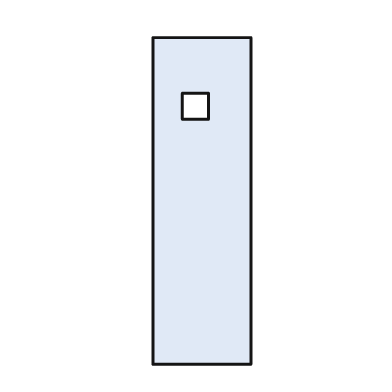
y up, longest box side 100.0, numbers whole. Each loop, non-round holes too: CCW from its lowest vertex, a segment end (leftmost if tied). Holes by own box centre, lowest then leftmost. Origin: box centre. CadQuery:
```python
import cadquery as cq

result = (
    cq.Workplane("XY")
    .moveTo(-15.0, -50.0)
    .lineTo(15.0, -50.0)
    .lineTo(15.0, 50.0)
    .lineTo(-15.0, 50.0)
    .close()
    .moveTo(-6.0, 25.0)
    .lineTo(2.0, 25.0)
    .lineTo(2.0, 33.0)
    .lineTo(-6.0, 33.0)
    .close()
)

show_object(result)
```